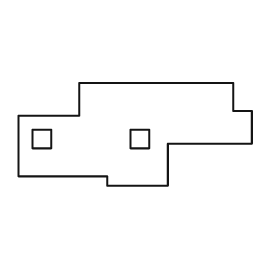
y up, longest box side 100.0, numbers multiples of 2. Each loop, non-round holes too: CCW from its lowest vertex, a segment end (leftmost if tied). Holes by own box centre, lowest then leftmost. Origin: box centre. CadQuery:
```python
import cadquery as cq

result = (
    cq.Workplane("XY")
    .moveTo(-12.0, -22.0)
    .lineTo(14.0, -22.0)
    .lineTo(14.0, -4.0)
    .lineTo(50.0, -4.0)
    .lineTo(50.0, 10.0)
    .lineTo(42.0, 10.0)
    .lineTo(42.0, 22.0)
    .lineTo(-24.0, 22.0)
    .lineTo(-24.0, 8.0)
    .lineTo(-50.0, 8.0)
    .lineTo(-50.0, -18.0)
    .lineTo(-12.0, -18.0)
    .close()
    .moveTo(-44.0, -6.0)
    .lineTo(-36.0, -6.0)
    .lineTo(-36.0, 2.0)
    .lineTo(-44.0, 2.0)
    .close()
    .moveTo(-2.0, -6.0)
    .lineTo(6.0, -6.0)
    .lineTo(6.0, 2.0)
    .lineTo(-2.0, 2.0)
    .close()
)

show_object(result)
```